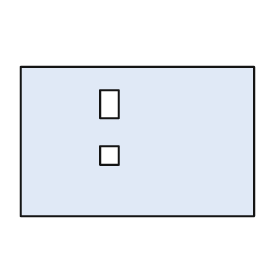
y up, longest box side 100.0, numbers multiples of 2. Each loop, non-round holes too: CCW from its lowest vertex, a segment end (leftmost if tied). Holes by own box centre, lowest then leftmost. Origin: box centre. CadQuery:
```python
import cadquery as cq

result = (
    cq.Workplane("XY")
    .moveTo(-50.0, -32.0)
    .lineTo(50.0, -32.0)
    .lineTo(50.0, 32.0)
    .lineTo(-50.0, 32.0)
    .close()
    .moveTo(-16.0, -10.0)
    .lineTo(-8.0, -10.0)
    .lineTo(-8.0, -2.0)
    .lineTo(-16.0, -2.0)
    .close()
    .moveTo(-16.0, 10.0)
    .lineTo(-8.0, 10.0)
    .lineTo(-8.0, 22.0)
    .lineTo(-16.0, 22.0)
    .close()
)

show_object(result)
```